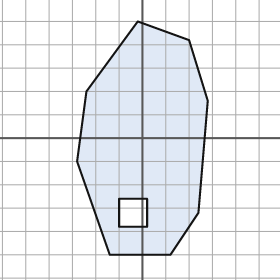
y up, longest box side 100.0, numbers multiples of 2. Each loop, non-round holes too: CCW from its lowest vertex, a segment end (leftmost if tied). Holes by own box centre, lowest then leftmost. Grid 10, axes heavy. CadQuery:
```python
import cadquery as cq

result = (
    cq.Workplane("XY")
    .moveTo(-14.0, -50.0)
    .lineTo(12.0, -50.0)
    .lineTo(24.0, -32.0)
    .lineTo(28.0, 16.0)
    .lineTo(20.0, 42.0)
    .lineTo(-2.0, 50.0)
    .lineTo(-24.0, 20.0)
    .lineTo(-28.0, -10.0)
    .close()
    .moveTo(-10.0, -38.0)
    .lineTo(2.0, -38.0)
    .lineTo(2.0, -26.0)
    .lineTo(-10.0, -26.0)
    .close()
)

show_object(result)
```